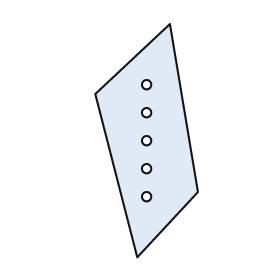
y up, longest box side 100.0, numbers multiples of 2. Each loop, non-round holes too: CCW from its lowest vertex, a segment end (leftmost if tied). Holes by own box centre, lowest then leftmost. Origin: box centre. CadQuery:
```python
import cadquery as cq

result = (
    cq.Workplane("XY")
    .moveTo(-4.0, -50.0)
    .lineTo(22.0, -22.0)
    .lineTo(10.0, 50.0)
    .lineTo(-22.0, 20.0)
    .close()
    .moveTo(0.0, -24.0)
    .circle(2.0)
    .moveTo(0.0, -12.0)
    .circle(2.0)
    .moveTo(0.0, 0.0)
    .circle(2.0)
    .moveTo(0.0, 12.0)
    .circle(2.0)
    .moveTo(0.0, 24.0)
    .circle(2.0)
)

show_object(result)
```